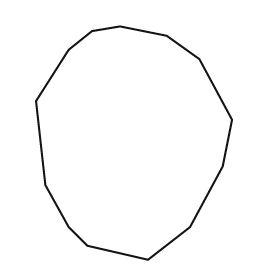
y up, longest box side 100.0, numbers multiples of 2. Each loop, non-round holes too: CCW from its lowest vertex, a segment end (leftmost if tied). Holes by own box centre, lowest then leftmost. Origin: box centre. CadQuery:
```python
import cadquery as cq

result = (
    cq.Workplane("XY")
    .moveTo(6.0, -50.0)
    .lineTo(24.0, -36.0)
    .lineTo(38.0, -10.0)
    .lineTo(42.0, 10.0)
    .lineTo(28.0, 36.0)
    .lineTo(14.0, 46.0)
    .lineTo(-6.0, 50.0)
    .lineTo(-18.0, 48.0)
    .lineTo(-28.0, 40.0)
    .lineTo(-42.0, 18.0)
    .lineTo(-38.0, -18.0)
    .lineTo(-28.0, -36.0)
    .lineTo(-20.0, -44.0)
    .close()
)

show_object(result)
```